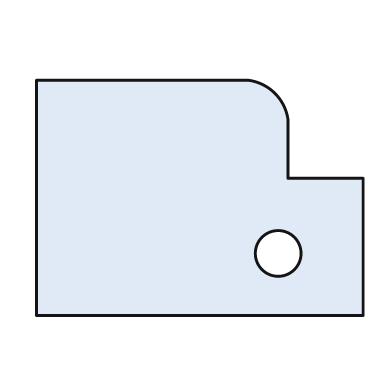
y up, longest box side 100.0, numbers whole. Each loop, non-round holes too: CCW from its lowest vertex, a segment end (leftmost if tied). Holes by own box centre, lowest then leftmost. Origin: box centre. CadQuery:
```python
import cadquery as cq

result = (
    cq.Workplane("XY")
    .moveTo(-50.0, -36.0)
    .lineTo(50.0, -36.0)
    .lineTo(50.0, 6.0)
    .lineTo(27.0, 6.0)
    .lineTo(27.0, 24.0)
    .threePointArc((23.0, 32.0), (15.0, 36.0))
    .lineTo(-50.0, 36.0)
    .close()
    .moveTo(24.0, -17.0)
    .circle(7.0)
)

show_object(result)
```